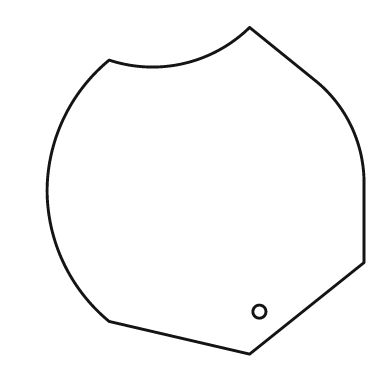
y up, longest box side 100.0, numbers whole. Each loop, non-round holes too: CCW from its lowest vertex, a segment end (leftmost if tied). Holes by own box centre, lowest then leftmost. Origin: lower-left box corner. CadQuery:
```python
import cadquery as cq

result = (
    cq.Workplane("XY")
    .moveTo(62.0, 0.0)
    .lineTo(97.0, 28.0)
    .lineTo(97.0, 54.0)
    .threePointArc((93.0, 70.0), (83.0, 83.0))
    .lineTo(62.0, 100.0)
    .threePointArc((42.0, 89.0), (19.0, 90.0))
    .threePointArc((5.0, 72.0), (0.0, 50.0))
    .threePointArc((5.0, 28.0), (19.0, 10.0))
    .close()
    .moveTo(65.0, 13.0)
    .circle(2.0)
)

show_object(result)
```